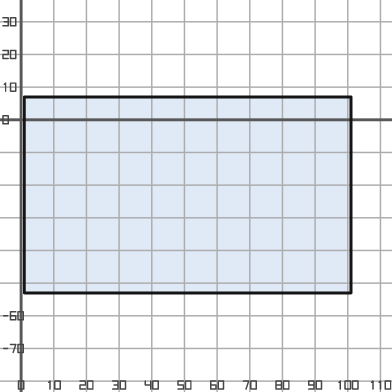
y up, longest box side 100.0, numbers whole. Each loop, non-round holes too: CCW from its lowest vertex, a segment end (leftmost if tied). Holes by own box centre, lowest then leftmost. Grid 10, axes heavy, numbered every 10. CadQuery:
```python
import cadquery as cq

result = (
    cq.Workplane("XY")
    .moveTo(1.0, -53.0)
    .lineTo(101.0, -53.0)
    .lineTo(101.0, 7.0)
    .lineTo(1.0, 7.0)
    .close()
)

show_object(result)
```